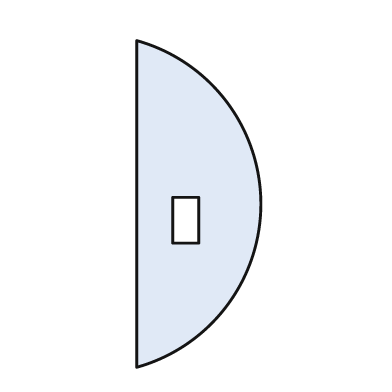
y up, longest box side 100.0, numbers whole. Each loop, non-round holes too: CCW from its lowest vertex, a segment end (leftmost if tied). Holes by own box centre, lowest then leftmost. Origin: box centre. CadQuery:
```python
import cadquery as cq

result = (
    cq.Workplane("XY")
    .moveTo(-19.0, -50.0)
    .threePointArc((19.0, 0.0), (-19.0, 50.0))
    .close()
    .moveTo(-8.0, -12.0)
    .lineTo(0.0, -12.0)
    .lineTo(0.0, 2.0)
    .lineTo(-8.0, 2.0)
    .close()
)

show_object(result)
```